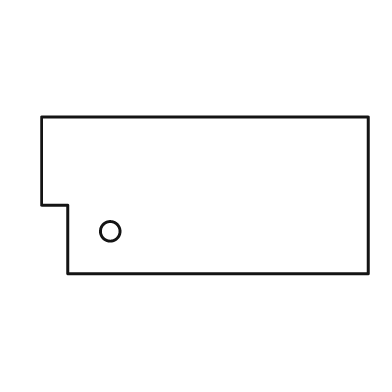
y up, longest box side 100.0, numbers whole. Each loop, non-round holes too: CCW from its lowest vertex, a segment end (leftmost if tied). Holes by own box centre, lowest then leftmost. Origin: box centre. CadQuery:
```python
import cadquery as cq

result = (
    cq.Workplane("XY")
    .moveTo(-42.0, -24.0)
    .lineTo(50.0, -24.0)
    .lineTo(50.0, 24.0)
    .lineTo(-50.0, 24.0)
    .lineTo(-50.0, -3.0)
    .lineTo(-42.0, -3.0)
    .close()
    .moveTo(-29.0, -11.0)
    .circle(3.0)
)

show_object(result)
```